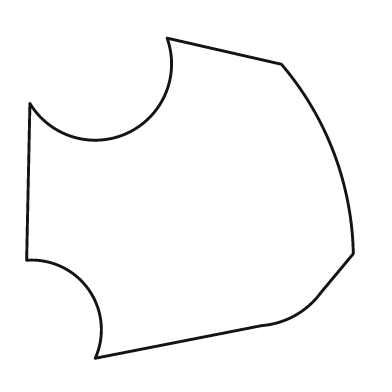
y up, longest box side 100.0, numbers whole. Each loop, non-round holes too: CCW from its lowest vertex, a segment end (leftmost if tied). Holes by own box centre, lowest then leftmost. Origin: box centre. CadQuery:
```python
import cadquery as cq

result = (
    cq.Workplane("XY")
    .moveTo(-29.0, -49.0)
    .lineTo(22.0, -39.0)
    .threePointArc((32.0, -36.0), (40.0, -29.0))
    .lineTo(50.0, -17.0)
    .threePointArc((44.0, 14.0), (28.0, 41.0))
    .lineTo(-7.0, 49.0)
    .threePointArc((-19.0, 20.0), (-49.0, 29.0))
    .lineTo(-50.0, -19.0)
    .threePointArc((-31.0, -28.0), (-29.0, -49.0))
    .close()
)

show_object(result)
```